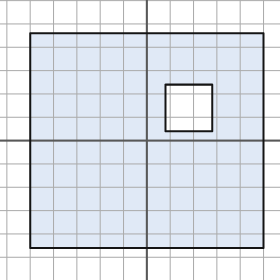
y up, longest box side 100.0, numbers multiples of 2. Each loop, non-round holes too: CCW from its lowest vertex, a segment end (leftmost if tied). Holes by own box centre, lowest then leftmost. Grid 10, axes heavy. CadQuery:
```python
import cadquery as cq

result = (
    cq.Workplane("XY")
    .moveTo(-50.0, -46.0)
    .lineTo(50.0, -46.0)
    .lineTo(50.0, 46.0)
    .lineTo(-50.0, 46.0)
    .close()
    .moveTo(8.0, 4.0)
    .lineTo(28.0, 4.0)
    .lineTo(28.0, 24.0)
    .lineTo(8.0, 24.0)
    .close()
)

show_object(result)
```